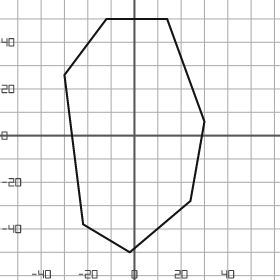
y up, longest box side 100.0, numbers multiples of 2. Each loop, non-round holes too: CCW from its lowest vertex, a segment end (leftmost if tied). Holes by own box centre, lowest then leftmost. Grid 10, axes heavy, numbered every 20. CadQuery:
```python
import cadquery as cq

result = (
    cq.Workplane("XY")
    .moveTo(-2.0, -50.0)
    .lineTo(24.0, -28.0)
    .lineTo(30.0, 6.0)
    .lineTo(14.0, 50.0)
    .lineTo(-12.0, 50.0)
    .lineTo(-30.0, 26.0)
    .lineTo(-22.0, -38.0)
    .close()
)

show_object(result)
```